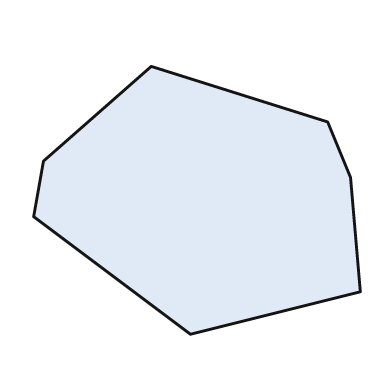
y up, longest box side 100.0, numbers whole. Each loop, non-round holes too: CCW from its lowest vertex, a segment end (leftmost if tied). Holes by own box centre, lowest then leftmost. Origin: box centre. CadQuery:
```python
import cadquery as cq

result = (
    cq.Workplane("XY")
    .moveTo(-2.0, -41.0)
    .lineTo(50.0, -28.0)
    .lineTo(47.0, 7.0)
    .lineTo(40.0, 24.0)
    .lineTo(-14.0, 41.0)
    .lineTo(-47.0, 12.0)
    .lineTo(-50.0, -5.0)
    .close()
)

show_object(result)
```